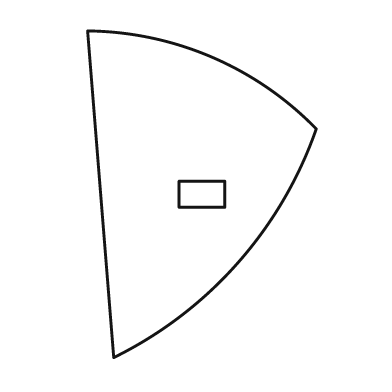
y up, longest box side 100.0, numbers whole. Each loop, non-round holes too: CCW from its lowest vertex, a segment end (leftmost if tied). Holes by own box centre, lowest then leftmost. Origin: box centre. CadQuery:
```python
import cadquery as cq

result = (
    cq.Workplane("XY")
    .moveTo(-27.0, -50.0)
    .threePointArc((11.0, -21.0), (35.0, 20.0))
    .threePointArc((3.0, 42.0), (-35.0, 50.0))
    .close()
    .moveTo(-7.0, -4.0)
    .lineTo(7.0, -4.0)
    .lineTo(7.0, 4.0)
    .lineTo(-7.0, 4.0)
    .close()
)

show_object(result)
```